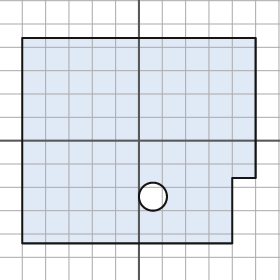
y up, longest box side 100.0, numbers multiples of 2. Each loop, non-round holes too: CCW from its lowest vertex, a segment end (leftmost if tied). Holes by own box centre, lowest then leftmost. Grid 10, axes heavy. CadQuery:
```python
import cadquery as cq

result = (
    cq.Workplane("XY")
    .moveTo(-50.0, -44.0)
    .lineTo(40.0, -44.0)
    .lineTo(40.0, -16.0)
    .lineTo(50.0, -16.0)
    .lineTo(50.0, 44.0)
    .lineTo(-50.0, 44.0)
    .close()
    .moveTo(6.0, -24.0)
    .circle(6.0)
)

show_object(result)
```